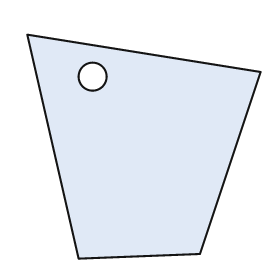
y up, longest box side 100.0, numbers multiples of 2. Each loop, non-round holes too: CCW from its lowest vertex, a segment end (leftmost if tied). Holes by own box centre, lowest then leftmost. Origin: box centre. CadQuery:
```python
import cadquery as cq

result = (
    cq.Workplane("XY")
    .moveTo(-28.0, -48.0)
    .lineTo(24.0, -46.0)
    .lineTo(50.0, 32.0)
    .lineTo(-50.0, 48.0)
    .close()
    .moveTo(-22.0, 30.0)
    .circle(6.0)
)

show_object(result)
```